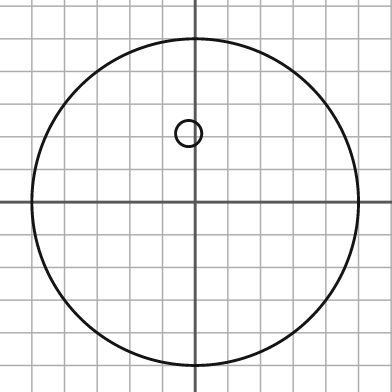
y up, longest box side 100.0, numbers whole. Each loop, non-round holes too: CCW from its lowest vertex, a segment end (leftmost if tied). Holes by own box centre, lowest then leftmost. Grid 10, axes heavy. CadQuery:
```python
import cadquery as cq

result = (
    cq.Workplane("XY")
    .moveTo(0.0, 0.0)
    .circle(50.0)
    .moveTo(-2.0, 21.0)
    .circle(4.0)
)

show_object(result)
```